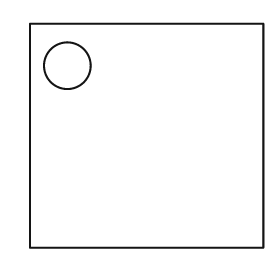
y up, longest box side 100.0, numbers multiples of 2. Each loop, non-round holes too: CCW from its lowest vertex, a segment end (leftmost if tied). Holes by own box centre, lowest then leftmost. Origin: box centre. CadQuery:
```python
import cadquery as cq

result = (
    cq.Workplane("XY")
    .moveTo(-50.0, -48.0)
    .lineTo(50.0, -48.0)
    .lineTo(50.0, 48.0)
    .lineTo(-50.0, 48.0)
    .close()
    .moveTo(-34.0, 30.0)
    .circle(10.0)
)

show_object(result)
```